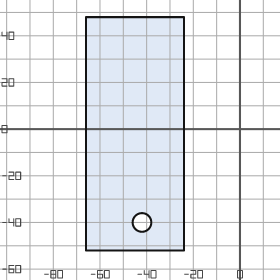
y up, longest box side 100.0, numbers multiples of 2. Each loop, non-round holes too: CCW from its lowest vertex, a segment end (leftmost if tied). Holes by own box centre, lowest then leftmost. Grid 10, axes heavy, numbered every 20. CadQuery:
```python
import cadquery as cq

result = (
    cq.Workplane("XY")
    .moveTo(-66.0, -52.0)
    .lineTo(-24.0, -52.0)
    .lineTo(-24.0, 48.0)
    .lineTo(-66.0, 48.0)
    .close()
    .moveTo(-42.0, -40.0)
    .circle(4.0)
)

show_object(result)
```